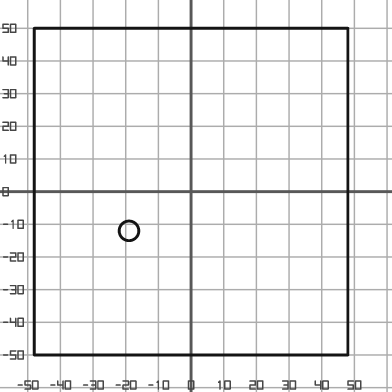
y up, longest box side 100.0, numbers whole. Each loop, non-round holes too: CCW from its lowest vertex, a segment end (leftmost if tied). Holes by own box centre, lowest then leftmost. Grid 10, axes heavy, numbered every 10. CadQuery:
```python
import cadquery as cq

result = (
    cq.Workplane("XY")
    .moveTo(-48.0, -50.0)
    .lineTo(48.0, -50.0)
    .lineTo(48.0, 50.0)
    .lineTo(-48.0, 50.0)
    .close()
    .moveTo(-19.0, -12.0)
    .circle(3.0)
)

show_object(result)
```